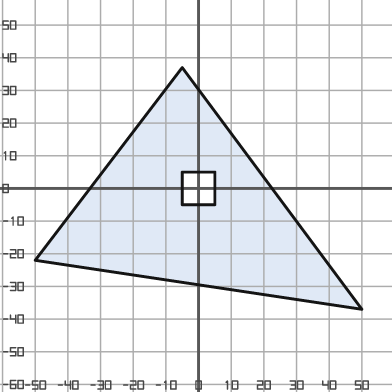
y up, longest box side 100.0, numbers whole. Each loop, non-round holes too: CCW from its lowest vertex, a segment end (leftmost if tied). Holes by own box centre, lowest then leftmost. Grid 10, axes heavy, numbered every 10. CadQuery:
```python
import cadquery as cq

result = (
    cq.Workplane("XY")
    .moveTo(50.0, -37.0)
    .lineTo(-5.0, 37.0)
    .lineTo(-50.0, -22.0)
    .close()
    .moveTo(-5.0, -5.0)
    .lineTo(5.0, -5.0)
    .lineTo(5.0, 5.0)
    .lineTo(-5.0, 5.0)
    .close()
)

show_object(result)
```